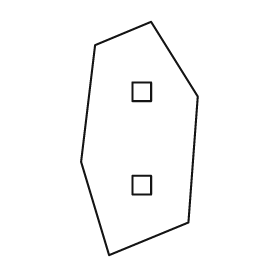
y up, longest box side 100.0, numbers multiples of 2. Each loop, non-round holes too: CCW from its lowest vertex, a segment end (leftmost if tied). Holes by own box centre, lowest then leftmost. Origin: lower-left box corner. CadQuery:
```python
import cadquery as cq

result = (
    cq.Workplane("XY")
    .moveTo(12.0, 0.0)
    .lineTo(46.0, 14.0)
    .lineTo(50.0, 68.0)
    .lineTo(30.0, 100.0)
    .lineTo(6.0, 90.0)
    .lineTo(0.0, 40.0)
    .close()
    .moveTo(22.0, 26.0)
    .lineTo(30.0, 26.0)
    .lineTo(30.0, 34.0)
    .lineTo(22.0, 34.0)
    .close()
    .moveTo(22.0, 66.0)
    .lineTo(30.0, 66.0)
    .lineTo(30.0, 74.0)
    .lineTo(22.0, 74.0)
    .close()
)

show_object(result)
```